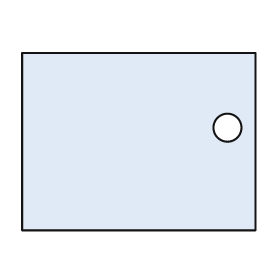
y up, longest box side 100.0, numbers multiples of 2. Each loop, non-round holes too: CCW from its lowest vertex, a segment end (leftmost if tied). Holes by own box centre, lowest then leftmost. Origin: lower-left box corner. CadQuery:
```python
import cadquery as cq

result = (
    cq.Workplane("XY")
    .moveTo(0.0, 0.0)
    .lineTo(100.0, 0.0)
    .lineTo(100.0, 76.0)
    .lineTo(0.0, 76.0)
    .close()
    .moveTo(88.0, 44.0)
    .circle(6.0)
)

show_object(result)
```